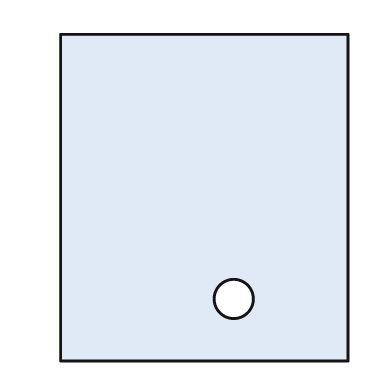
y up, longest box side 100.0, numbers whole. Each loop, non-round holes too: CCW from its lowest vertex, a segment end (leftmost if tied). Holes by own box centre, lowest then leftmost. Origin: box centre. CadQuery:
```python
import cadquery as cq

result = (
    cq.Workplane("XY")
    .moveTo(-44.0, -50.0)
    .lineTo(44.0, -50.0)
    .lineTo(44.0, 50.0)
    .lineTo(-44.0, 50.0)
    .close()
    .moveTo(9.0, -31.0)
    .circle(6.0)
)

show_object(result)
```